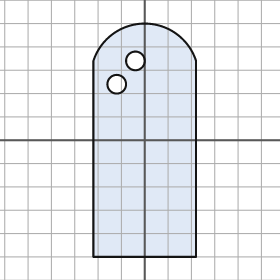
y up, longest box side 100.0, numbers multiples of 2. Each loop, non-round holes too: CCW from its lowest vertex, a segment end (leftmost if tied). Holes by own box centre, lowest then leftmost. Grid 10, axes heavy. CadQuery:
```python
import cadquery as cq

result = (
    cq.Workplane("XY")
    .moveTo(-22.0, -50.0)
    .lineTo(22.0, -50.0)
    .lineTo(22.0, 34.0)
    .threePointArc((0.0, 50.0), (-22.0, 34.0))
    .close()
    .moveTo(-12.0, 24.0)
    .circle(4.0)
    .moveTo(-4.0, 34.0)
    .circle(4.0)
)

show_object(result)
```